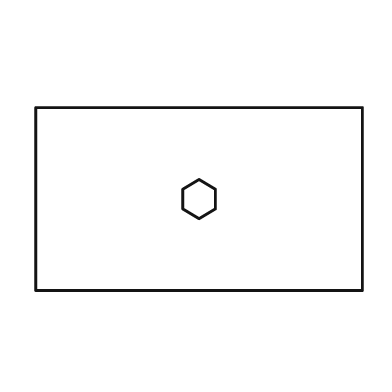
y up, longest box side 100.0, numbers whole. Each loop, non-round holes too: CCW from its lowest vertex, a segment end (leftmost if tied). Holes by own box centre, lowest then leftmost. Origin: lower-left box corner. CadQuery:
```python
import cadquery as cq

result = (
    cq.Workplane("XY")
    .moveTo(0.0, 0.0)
    .lineTo(100.0, 0.0)
    .lineTo(100.0, 56.0)
    .lineTo(0.0, 56.0)
    .close()
    .moveTo(50.0, 22.0)
    .lineTo(55.0, 25.0)
    .lineTo(55.0, 31.0)
    .lineTo(50.0, 34.0)
    .lineTo(45.0, 31.0)
    .lineTo(45.0, 25.0)
    .close()
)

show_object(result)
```